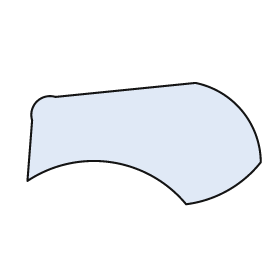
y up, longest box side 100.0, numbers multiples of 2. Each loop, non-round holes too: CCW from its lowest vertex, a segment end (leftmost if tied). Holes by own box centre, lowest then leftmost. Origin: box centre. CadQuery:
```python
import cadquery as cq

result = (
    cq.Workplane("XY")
    .moveTo(18.0, -26.0)
    .threePointArc((36.0, -20.0), (50.0, -8.0))
    .threePointArc((42.0, 14.0), (22.0, 26.0))
    .lineTo(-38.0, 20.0)
    .threePointArc((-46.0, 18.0), (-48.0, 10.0))
    .lineTo(-50.0, -16.0)
    .threePointArc((-14.0, -8.0), (18.0, -26.0))
    .close()
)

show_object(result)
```